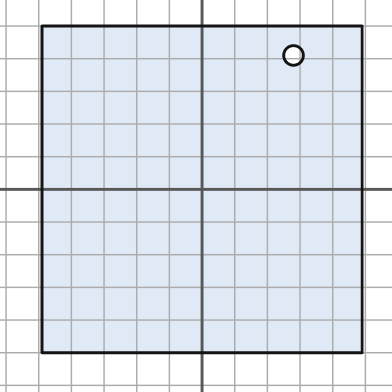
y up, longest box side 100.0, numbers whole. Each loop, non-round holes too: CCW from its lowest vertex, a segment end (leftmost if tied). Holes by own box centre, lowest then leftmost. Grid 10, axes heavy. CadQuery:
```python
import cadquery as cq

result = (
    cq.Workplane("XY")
    .moveTo(-49.0, -50.0)
    .lineTo(49.0, -50.0)
    .lineTo(49.0, 50.0)
    .lineTo(-49.0, 50.0)
    .close()
    .moveTo(28.0, 41.0)
    .circle(3.0)
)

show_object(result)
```